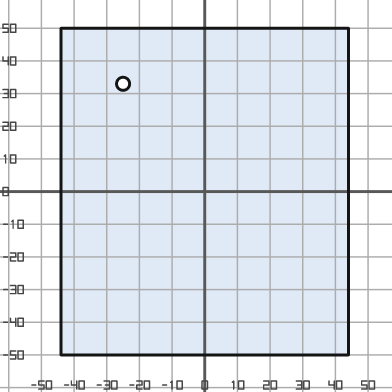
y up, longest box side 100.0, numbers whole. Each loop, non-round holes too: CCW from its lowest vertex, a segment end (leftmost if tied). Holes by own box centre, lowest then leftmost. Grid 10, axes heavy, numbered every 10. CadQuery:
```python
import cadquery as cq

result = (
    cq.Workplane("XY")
    .moveTo(-44.0, -50.0)
    .lineTo(44.0, -50.0)
    .lineTo(44.0, 50.0)
    .lineTo(-44.0, 50.0)
    .close()
    .moveTo(-25.0, 33.0)
    .circle(2.0)
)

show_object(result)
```